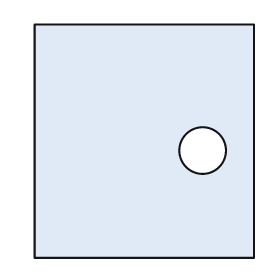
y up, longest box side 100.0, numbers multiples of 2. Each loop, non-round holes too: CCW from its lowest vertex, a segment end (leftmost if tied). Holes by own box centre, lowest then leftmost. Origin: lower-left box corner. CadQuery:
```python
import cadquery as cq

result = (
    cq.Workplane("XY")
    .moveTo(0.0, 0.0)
    .lineTo(94.0, 0.0)
    .lineTo(94.0, 100.0)
    .lineTo(0.0, 100.0)
    .close()
    .moveTo(72.0, 46.0)
    .circle(10.0)
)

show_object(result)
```